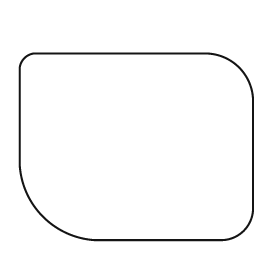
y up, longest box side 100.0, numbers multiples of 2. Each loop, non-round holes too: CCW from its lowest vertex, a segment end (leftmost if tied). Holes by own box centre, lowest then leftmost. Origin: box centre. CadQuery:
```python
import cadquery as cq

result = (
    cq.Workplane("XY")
    .moveTo(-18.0, -40.0)
    .lineTo(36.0, -40.0)
    .threePointArc((46.0, -36.0), (50.0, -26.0))
    .lineTo(50.0, 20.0)
    .threePointArc((44.0, 34.0), (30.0, 40.0))
    .lineTo(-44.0, 40.0)
    .threePointArc((-48.0, 38.0), (-50.0, 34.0))
    .lineTo(-50.0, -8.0)
    .threePointArc((-40.0, -30.0), (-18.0, -40.0))
    .close()
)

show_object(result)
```